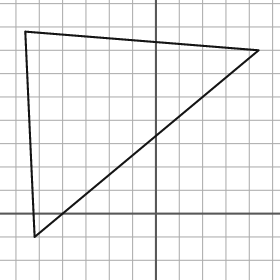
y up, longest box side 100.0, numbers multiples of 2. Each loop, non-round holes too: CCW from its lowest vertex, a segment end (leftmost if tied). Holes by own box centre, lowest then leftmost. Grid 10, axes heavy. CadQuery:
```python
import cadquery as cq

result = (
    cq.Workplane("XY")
    .moveTo(-52.0, -10.0)
    .lineTo(44.0, 70.0)
    .lineTo(-56.0, 78.0)
    .close()
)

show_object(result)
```